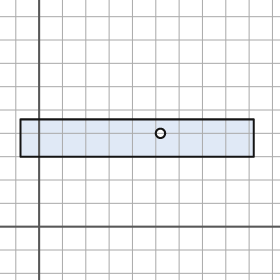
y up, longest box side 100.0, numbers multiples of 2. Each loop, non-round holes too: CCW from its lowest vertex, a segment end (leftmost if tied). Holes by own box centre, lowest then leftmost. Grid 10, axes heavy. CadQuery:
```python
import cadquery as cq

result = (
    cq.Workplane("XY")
    .moveTo(-8.0, 30.0)
    .lineTo(92.0, 30.0)
    .lineTo(92.0, 46.0)
    .lineTo(-8.0, 46.0)
    .close()
    .moveTo(52.0, 40.0)
    .circle(2.0)
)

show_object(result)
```